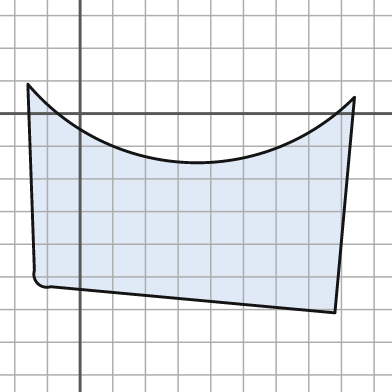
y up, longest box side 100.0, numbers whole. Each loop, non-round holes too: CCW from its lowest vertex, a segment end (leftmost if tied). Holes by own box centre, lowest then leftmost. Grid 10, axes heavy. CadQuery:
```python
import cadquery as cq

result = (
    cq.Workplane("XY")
    .moveTo(78.0, -61.0)
    .lineTo(84.0, 5.0)
    .threePointArc((33.0, -15.0), (-16.0, 9.0))
    .lineTo(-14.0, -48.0)
    .threePointArc((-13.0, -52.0), (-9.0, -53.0))
    .close()
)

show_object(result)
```